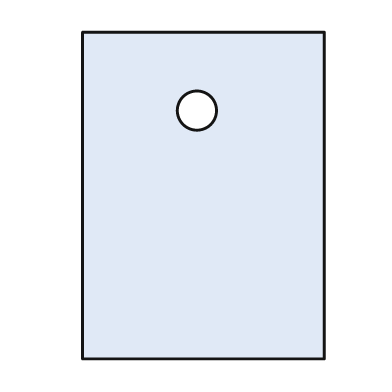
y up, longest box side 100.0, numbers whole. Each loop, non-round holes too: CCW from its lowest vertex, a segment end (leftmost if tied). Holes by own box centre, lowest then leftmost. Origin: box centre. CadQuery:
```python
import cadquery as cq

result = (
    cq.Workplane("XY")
    .moveTo(-37.0, -50.0)
    .lineTo(37.0, -50.0)
    .lineTo(37.0, 50.0)
    .lineTo(-37.0, 50.0)
    .close()
    .moveTo(-2.0, 26.0)
    .circle(6.0)
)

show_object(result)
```